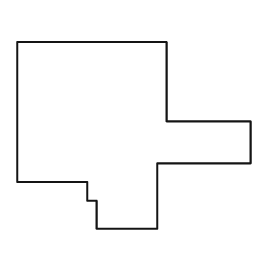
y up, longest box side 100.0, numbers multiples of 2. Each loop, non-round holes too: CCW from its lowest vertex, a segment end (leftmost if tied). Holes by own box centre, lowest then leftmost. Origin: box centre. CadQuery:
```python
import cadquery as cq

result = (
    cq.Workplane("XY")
    .moveTo(-16.0, -40.0)
    .lineTo(10.0, -40.0)
    .lineTo(10.0, -12.0)
    .lineTo(50.0, -12.0)
    .lineTo(50.0, 6.0)
    .lineTo(14.0, 6.0)
    .lineTo(14.0, 40.0)
    .lineTo(-50.0, 40.0)
    .lineTo(-50.0, -20.0)
    .lineTo(-20.0, -20.0)
    .lineTo(-20.0, -28.0)
    .lineTo(-16.0, -28.0)
    .close()
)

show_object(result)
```